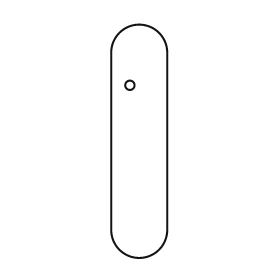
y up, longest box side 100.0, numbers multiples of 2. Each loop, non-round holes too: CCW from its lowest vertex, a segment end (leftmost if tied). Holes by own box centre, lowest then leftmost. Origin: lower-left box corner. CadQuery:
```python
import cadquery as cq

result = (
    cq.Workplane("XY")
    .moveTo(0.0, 12.0)
    .threePointArc((12.0, 0.0), (24.0, 12.0))
    .lineTo(24.0, 88.0)
    .threePointArc((12.0, 100.0), (0.0, 88.0))
    .close()
    .moveTo(8.0, 74.0)
    .circle(2.0)
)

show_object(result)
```